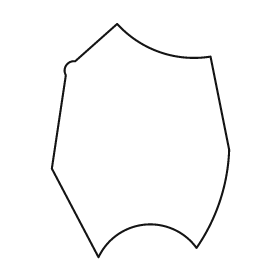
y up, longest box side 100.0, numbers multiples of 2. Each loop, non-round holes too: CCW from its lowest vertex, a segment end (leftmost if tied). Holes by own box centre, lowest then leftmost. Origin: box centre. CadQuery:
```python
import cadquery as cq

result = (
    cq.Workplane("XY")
    .moveTo(-18.0, -50.0)
    .threePointArc((2.0, -36.0), (24.0, -46.0))
    .threePointArc((34.0, -26.0), (38.0, -4.0))
    .lineTo(30.0, 36.0)
    .threePointArc((8.0, 38.0), (-10.0, 50.0))
    .lineTo(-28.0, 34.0)
    .threePointArc((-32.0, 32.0), (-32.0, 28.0))
    .lineTo(-38.0, -12.0)
    .close()
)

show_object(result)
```